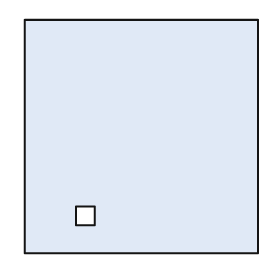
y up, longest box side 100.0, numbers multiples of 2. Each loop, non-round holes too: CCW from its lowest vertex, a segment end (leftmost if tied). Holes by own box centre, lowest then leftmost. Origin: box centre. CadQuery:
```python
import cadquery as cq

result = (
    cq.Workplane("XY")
    .moveTo(-50.0, -50.0)
    .lineTo(50.0, -50.0)
    .lineTo(50.0, 50.0)
    .lineTo(-50.0, 50.0)
    .close()
    .moveTo(-28.0, -38.0)
    .lineTo(-20.0, -38.0)
    .lineTo(-20.0, -30.0)
    .lineTo(-28.0, -30.0)
    .close()
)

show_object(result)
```